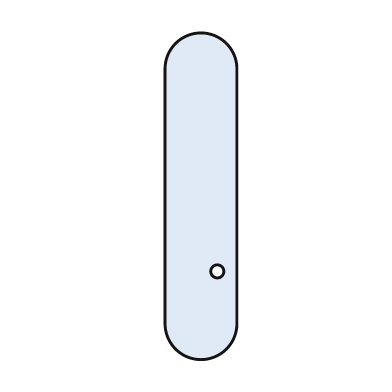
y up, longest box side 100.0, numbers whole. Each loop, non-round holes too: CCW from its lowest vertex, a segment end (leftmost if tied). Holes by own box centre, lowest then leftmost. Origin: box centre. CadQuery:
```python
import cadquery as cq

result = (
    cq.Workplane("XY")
    .moveTo(-11.0, -39.0)
    .threePointArc((0.0, -50.0), (11.0, -39.0))
    .lineTo(11.0, 39.0)
    .threePointArc((0.0, 50.0), (-11.0, 39.0))
    .close()
    .moveTo(5.0, -23.0)
    .circle(2.0)
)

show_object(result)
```